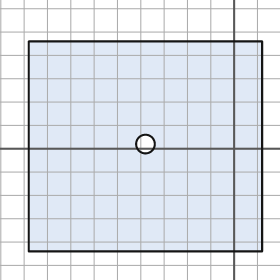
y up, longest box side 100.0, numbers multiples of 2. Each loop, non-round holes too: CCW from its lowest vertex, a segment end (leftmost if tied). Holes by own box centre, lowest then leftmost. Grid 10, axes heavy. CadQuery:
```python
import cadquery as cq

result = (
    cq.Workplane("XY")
    .moveTo(-88.0, -44.0)
    .lineTo(12.0, -44.0)
    .lineTo(12.0, 46.0)
    .lineTo(-88.0, 46.0)
    .close()
    .moveTo(-38.0, 2.0)
    .circle(4.0)
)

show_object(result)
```